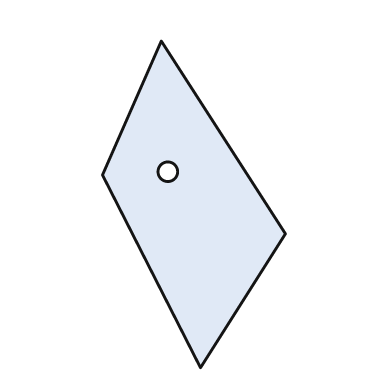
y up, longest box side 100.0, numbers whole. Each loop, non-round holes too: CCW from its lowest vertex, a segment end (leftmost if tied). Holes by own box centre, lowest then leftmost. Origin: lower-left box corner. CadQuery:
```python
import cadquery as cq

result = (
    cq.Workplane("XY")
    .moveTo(30.0, 0.0)
    .lineTo(56.0, 41.0)
    .lineTo(18.0, 100.0)
    .lineTo(0.0, 59.0)
    .close()
    .moveTo(20.0, 60.0)
    .circle(3.0)
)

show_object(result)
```